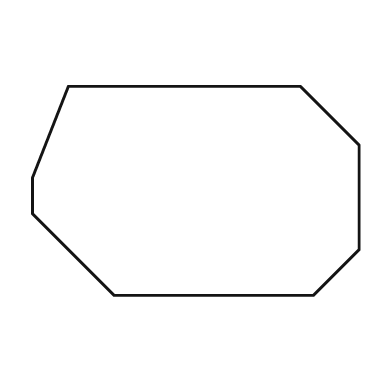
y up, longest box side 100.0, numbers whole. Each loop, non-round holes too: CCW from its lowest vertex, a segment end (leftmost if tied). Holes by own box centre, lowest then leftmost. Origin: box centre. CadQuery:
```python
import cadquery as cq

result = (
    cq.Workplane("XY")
    .moveTo(-25.0, -32.0)
    .lineTo(36.0, -32.0)
    .lineTo(50.0, -18.0)
    .lineTo(50.0, 14.0)
    .lineTo(32.0, 32.0)
    .lineTo(-39.0, 32.0)
    .lineTo(-50.0, 4.0)
    .lineTo(-50.0, -7.0)
    .close()
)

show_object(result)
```